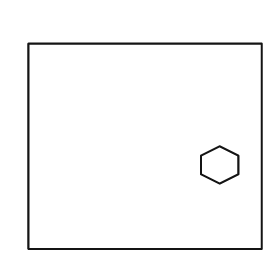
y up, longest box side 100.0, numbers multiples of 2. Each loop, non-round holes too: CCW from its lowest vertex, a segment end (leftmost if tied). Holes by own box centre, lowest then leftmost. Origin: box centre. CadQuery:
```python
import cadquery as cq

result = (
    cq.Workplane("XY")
    .moveTo(-50.0, -44.0)
    .lineTo(50.0, -44.0)
    .lineTo(50.0, 44.0)
    .lineTo(-50.0, 44.0)
    .close()
    .moveTo(32.0, -16.0)
    .lineTo(40.0, -12.0)
    .lineTo(40.0, -4.0)
    .lineTo(32.0, 0.0)
    .lineTo(24.0, -4.0)
    .lineTo(24.0, -12.0)
    .close()
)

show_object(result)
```